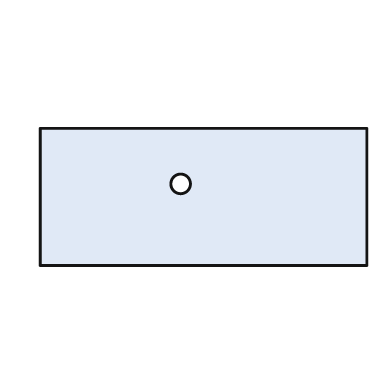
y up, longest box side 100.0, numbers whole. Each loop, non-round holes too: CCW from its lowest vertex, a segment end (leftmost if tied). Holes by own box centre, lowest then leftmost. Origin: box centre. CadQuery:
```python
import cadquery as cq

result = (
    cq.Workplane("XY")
    .moveTo(-50.0, -21.0)
    .lineTo(50.0, -21.0)
    .lineTo(50.0, 21.0)
    .lineTo(-50.0, 21.0)
    .close()
    .moveTo(-7.0, 4.0)
    .circle(3.0)
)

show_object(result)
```